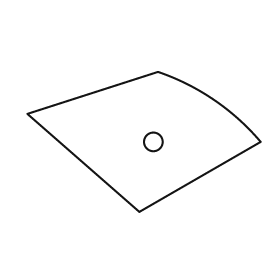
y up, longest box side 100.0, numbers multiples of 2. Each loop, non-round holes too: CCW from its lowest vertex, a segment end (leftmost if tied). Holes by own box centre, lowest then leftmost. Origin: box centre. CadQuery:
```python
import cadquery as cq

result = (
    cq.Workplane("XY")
    .moveTo(-2.0, -30.0)
    .lineTo(50.0, 0.0)
    .threePointArc((30.0, 18.0), (6.0, 30.0))
    .lineTo(-50.0, 12.0)
    .close()
    .moveTo(4.0, 0.0)
    .circle(4.0)
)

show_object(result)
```